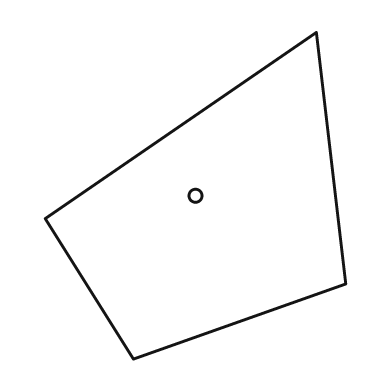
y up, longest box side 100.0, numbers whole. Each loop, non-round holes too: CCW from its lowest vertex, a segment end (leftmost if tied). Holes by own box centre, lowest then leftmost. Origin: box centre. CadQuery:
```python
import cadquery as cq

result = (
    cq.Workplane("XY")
    .moveTo(-19.0, -50.0)
    .lineTo(46.0, -27.0)
    .lineTo(37.0, 50.0)
    .lineTo(-46.0, -7.0)
    .close()
    .moveTo(0.0, 0.0)
    .circle(2.0)
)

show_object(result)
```